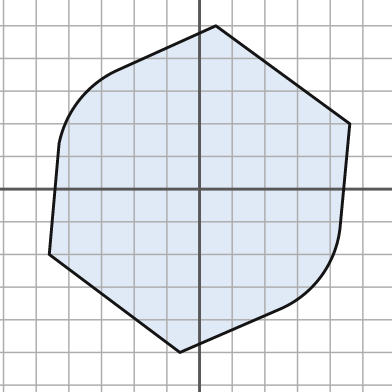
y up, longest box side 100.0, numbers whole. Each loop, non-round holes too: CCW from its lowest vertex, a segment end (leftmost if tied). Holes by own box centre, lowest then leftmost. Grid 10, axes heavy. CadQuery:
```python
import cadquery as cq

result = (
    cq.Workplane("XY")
    .moveTo(-6.0, -50.0)
    .lineTo(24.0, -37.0)
    .threePointArc((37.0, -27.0), (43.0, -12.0))
    .lineTo(46.0, 20.0)
    .lineTo(5.0, 50.0)
    .lineTo(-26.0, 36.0)
    .threePointArc((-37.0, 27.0), (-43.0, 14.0))
    .lineTo(-46.0, -20.0)
    .close()
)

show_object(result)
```